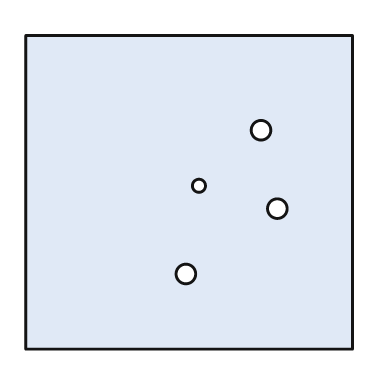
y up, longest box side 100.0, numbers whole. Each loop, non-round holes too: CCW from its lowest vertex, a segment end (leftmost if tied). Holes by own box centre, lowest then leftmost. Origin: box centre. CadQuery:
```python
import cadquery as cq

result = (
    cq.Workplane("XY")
    .moveTo(-50.0, -48.0)
    .lineTo(50.0, -48.0)
    .lineTo(50.0, 48.0)
    .lineTo(-50.0, 48.0)
    .close()
    .moveTo(-1.0, -25.0)
    .circle(3.0)
    .moveTo(27.0, -5.0)
    .circle(3.0)
    .moveTo(3.0, 2.0)
    .circle(2.0)
    .moveTo(22.0, 19.0)
    .circle(3.0)
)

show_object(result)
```